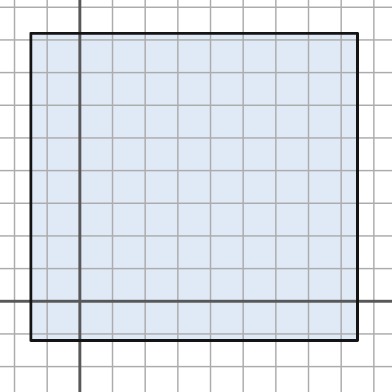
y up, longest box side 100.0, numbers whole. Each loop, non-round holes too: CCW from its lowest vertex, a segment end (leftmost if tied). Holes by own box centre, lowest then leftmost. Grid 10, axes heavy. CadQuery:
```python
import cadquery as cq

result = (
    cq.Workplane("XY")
    .moveTo(-15.0, -12.0)
    .lineTo(85.0, -12.0)
    .lineTo(85.0, 82.0)
    .lineTo(-15.0, 82.0)
    .close()
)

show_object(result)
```